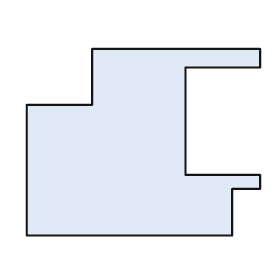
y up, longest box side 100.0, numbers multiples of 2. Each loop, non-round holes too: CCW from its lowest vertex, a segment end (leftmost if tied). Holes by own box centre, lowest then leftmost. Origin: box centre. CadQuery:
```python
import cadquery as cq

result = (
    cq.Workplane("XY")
    .moveTo(-50.0, -40.0)
    .lineTo(38.0, -40.0)
    .lineTo(38.0, -20.0)
    .lineTo(50.0, -20.0)
    .lineTo(50.0, -14.0)
    .lineTo(18.0, -14.0)
    .lineTo(18.0, 32.0)
    .lineTo(50.0, 32.0)
    .lineTo(50.0, 40.0)
    .lineTo(-22.0, 40.0)
    .lineTo(-22.0, 16.0)
    .lineTo(-50.0, 16.0)
    .close()
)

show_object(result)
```